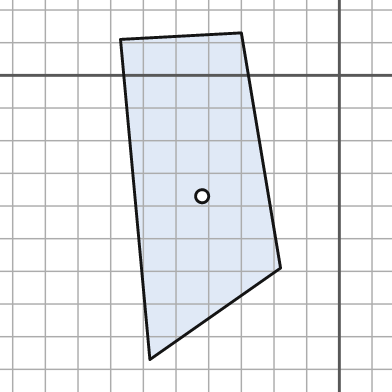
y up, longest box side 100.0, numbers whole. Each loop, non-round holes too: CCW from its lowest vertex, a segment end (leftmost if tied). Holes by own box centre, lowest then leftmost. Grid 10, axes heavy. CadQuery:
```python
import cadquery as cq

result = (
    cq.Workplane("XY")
    .moveTo(-58.0, -87.0)
    .lineTo(-18.0, -59.0)
    .lineTo(-30.0, 13.0)
    .lineTo(-67.0, 11.0)
    .close()
    .moveTo(-42.0, -37.0)
    .circle(2.0)
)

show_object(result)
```